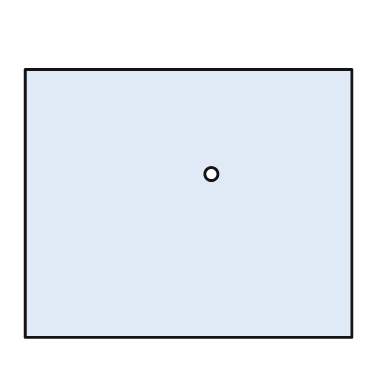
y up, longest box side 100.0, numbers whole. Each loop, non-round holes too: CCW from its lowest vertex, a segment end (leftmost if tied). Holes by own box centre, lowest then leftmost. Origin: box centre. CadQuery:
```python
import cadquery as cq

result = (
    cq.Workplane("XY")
    .moveTo(-50.0, -41.0)
    .lineTo(50.0, -41.0)
    .lineTo(50.0, 41.0)
    .lineTo(-50.0, 41.0)
    .close()
    .moveTo(7.0, 9.0)
    .circle(2.0)
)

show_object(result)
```